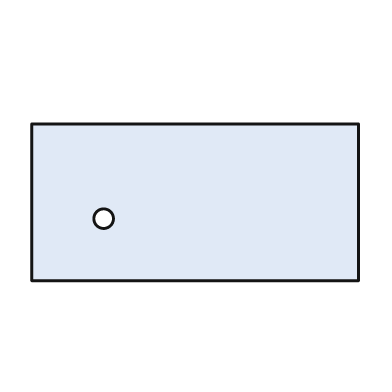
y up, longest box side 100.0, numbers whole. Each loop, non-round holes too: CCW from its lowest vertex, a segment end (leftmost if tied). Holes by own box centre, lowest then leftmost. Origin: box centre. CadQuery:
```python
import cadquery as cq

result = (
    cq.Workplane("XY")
    .moveTo(-50.0, -24.0)
    .lineTo(50.0, -24.0)
    .lineTo(50.0, 24.0)
    .lineTo(-50.0, 24.0)
    .close()
    .moveTo(-28.0, -5.0)
    .circle(3.0)
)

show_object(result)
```